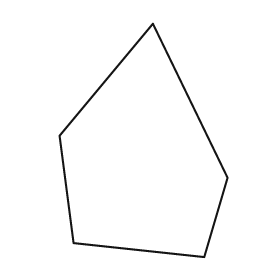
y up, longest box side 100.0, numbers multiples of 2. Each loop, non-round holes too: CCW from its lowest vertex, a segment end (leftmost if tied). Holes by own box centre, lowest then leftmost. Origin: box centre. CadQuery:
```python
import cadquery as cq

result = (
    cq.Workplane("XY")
    .moveTo(26.0, -50.0)
    .lineTo(36.0, -16.0)
    .lineTo(4.0, 50.0)
    .lineTo(-36.0, 2.0)
    .lineTo(-30.0, -44.0)
    .close()
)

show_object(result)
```